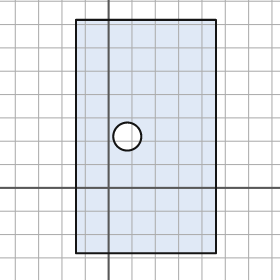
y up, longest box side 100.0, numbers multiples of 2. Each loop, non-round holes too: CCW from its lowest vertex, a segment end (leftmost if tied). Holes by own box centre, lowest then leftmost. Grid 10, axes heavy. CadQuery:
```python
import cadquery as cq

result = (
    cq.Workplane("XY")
    .moveTo(-14.0, -28.0)
    .lineTo(46.0, -28.0)
    .lineTo(46.0, 72.0)
    .lineTo(-14.0, 72.0)
    .close()
    .moveTo(8.0, 22.0)
    .circle(6.0)
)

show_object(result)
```